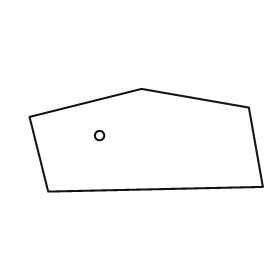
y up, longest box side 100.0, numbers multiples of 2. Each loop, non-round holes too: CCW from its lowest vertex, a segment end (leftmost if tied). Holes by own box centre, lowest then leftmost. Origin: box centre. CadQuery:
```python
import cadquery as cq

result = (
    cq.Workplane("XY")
    .moveTo(-42.0, -22.0)
    .lineTo(50.0, -20.0)
    .lineTo(44.0, 14.0)
    .lineTo(-2.0, 22.0)
    .lineTo(-50.0, 10.0)
    .close()
    .moveTo(-20.0, 2.0)
    .circle(2.0)
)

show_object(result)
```